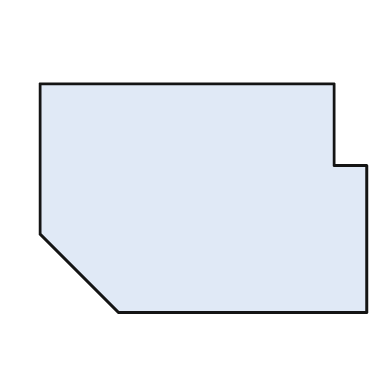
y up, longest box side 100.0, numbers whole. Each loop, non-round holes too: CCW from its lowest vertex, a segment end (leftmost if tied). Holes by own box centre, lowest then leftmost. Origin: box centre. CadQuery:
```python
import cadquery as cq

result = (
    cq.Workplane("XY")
    .moveTo(-26.0, -35.0)
    .lineTo(50.0, -35.0)
    .lineTo(50.0, 10.0)
    .lineTo(40.0, 10.0)
    .lineTo(40.0, 35.0)
    .lineTo(-50.0, 35.0)
    .lineTo(-50.0, -11.0)
    .close()
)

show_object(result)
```